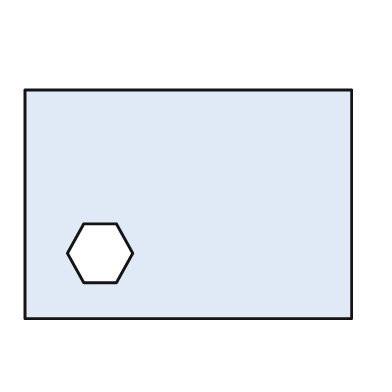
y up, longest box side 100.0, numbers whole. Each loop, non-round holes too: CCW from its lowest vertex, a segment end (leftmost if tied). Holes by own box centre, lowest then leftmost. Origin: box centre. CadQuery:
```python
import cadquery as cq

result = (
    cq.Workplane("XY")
    .moveTo(-50.0, -35.0)
    .lineTo(50.0, -35.0)
    .lineTo(50.0, 35.0)
    .lineTo(-50.0, 35.0)
    .close()
    .moveTo(-32.0, -24.0)
    .lineTo(-22.0, -24.0)
    .lineTo(-17.0, -15.0)
    .lineTo(-22.0, -6.0)
    .lineTo(-32.0, -6.0)
    .lineTo(-37.0, -15.0)
    .close()
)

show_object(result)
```